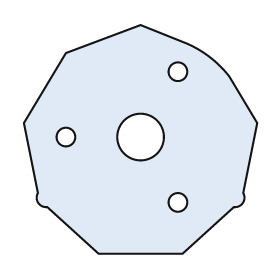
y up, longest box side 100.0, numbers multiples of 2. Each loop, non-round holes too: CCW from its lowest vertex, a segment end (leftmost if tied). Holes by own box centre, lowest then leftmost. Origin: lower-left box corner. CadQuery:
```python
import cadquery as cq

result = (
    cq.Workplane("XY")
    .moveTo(32.0, 0.0)
    .lineTo(68.0, 0.0)
    .lineTo(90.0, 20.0)
    .threePointArc((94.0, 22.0), (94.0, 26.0))
    .lineTo(100.0, 56.0)
    .lineTo(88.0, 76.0)
    .threePointArc((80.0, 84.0), (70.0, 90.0))
    .lineTo(50.0, 98.0)
    .lineTo(18.0, 86.0)
    .lineTo(0.0, 56.0)
    .lineTo(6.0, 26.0)
    .threePointArc((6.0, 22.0), (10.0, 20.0))
    .close()
    .moveTo(66.0, 22.0)
    .circle(4.0)
    .moveTo(18.0, 50.0)
    .circle(4.0)
    .moveTo(50.0, 50.0)
    .circle(10.0)
    .moveTo(66.0, 78.0)
    .circle(4.0)
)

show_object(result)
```